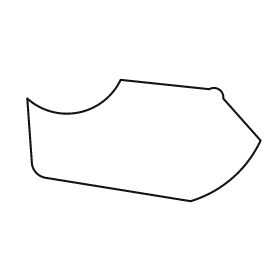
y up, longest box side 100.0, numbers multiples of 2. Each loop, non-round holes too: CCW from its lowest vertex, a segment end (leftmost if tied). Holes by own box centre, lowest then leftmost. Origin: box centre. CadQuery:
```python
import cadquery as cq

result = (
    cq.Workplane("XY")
    .moveTo(20.0, -26.0)
    .threePointArc((38.0, -16.0), (50.0, 0.0))
    .lineTo(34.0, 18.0)
    .threePointArc((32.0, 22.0), (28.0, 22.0))
    .lineTo(-10.0, 26.0)
    .threePointArc((-28.0, 12.0), (-50.0, 18.0))
    .lineTo(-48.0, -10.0)
    .threePointArc((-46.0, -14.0), (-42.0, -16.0))
    .close()
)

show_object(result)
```